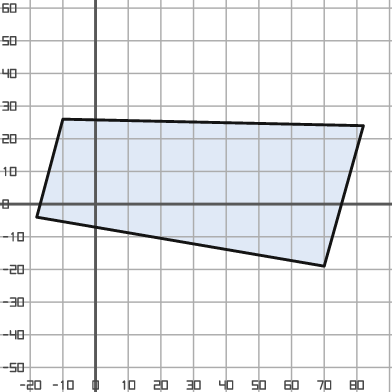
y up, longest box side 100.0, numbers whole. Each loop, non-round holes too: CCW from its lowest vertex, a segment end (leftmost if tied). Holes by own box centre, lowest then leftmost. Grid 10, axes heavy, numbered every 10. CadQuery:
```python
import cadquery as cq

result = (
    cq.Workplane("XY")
    .moveTo(70.0, -19.0)
    .lineTo(82.0, 24.0)
    .lineTo(-10.0, 26.0)
    .lineTo(-18.0, -4.0)
    .close()
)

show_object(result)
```